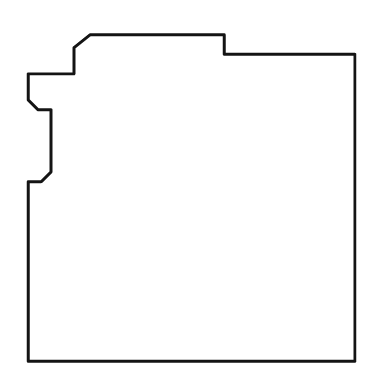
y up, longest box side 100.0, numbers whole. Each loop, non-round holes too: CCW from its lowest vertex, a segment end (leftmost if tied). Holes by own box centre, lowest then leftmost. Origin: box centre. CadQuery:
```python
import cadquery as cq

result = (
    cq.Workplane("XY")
    .moveTo(-50.0, -50.0)
    .lineTo(50.0, -50.0)
    .lineTo(50.0, 44.0)
    .lineTo(10.0, 44.0)
    .lineTo(10.0, 50.0)
    .lineTo(-31.0, 50.0)
    .lineTo(-36.0, 46.0)
    .lineTo(-36.0, 38.0)
    .lineTo(-50.0, 38.0)
    .lineTo(-50.0, 30.0)
    .lineTo(-47.0, 27.0)
    .lineTo(-43.0, 27.0)
    .lineTo(-43.0, 8.0)
    .lineTo(-46.0, 5.0)
    .lineTo(-50.0, 5.0)
    .close()
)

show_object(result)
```